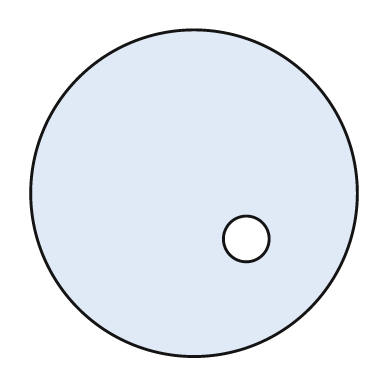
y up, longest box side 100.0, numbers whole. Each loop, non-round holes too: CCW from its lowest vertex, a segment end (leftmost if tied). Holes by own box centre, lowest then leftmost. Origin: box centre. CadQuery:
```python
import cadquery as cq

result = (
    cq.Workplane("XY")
    .moveTo(0.0, 0.0)
    .circle(50.0)
    .moveTo(16.0, -14.0)
    .circle(7.0)
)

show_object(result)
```